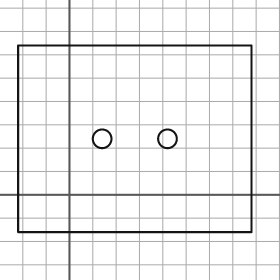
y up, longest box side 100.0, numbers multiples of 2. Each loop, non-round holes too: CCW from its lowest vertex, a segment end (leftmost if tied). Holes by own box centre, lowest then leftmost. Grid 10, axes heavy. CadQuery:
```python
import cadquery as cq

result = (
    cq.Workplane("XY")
    .moveTo(-22.0, -16.0)
    .lineTo(78.0, -16.0)
    .lineTo(78.0, 64.0)
    .lineTo(-22.0, 64.0)
    .close()
    .moveTo(14.0, 24.0)
    .circle(4.0)
    .moveTo(42.0, 24.0)
    .circle(4.0)
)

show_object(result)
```